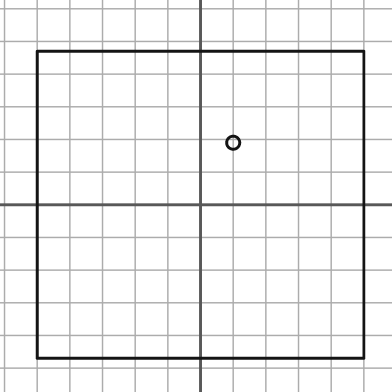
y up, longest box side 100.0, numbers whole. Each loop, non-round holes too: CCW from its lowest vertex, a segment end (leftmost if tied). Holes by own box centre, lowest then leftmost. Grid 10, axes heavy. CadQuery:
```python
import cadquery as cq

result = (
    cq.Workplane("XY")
    .moveTo(-50.0, -47.0)
    .lineTo(50.0, -47.0)
    .lineTo(50.0, 47.0)
    .lineTo(-50.0, 47.0)
    .close()
    .moveTo(10.0, 19.0)
    .circle(2.0)
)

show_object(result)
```